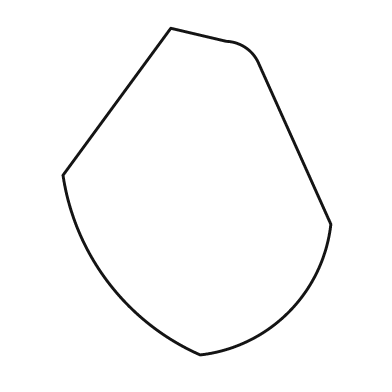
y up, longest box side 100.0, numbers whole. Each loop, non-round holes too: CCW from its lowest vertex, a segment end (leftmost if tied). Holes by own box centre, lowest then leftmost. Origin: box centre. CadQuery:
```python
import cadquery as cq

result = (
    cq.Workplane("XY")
    .moveTo(1.0, -50.0)
    .threePointArc((28.0, -37.0), (41.0, -10.0))
    .lineTo(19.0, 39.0)
    .threePointArc((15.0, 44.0), (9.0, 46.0))
    .lineTo(-8.0, 50.0)
    .lineTo(-41.0, 5.0)
    .threePointArc((-27.0, -28.0), (1.0, -50.0))
    .close()
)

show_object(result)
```